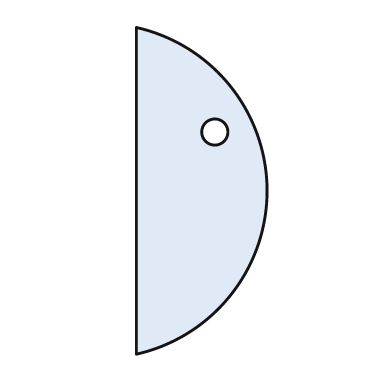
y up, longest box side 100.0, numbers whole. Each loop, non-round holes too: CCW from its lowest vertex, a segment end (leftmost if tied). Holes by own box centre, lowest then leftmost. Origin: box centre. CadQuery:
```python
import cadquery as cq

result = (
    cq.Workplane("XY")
    .moveTo(-20.0, -50.0)
    .threePointArc((20.0, 0.0), (-20.0, 50.0))
    .close()
    .moveTo(4.0, 18.0)
    .circle(4.0)
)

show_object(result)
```